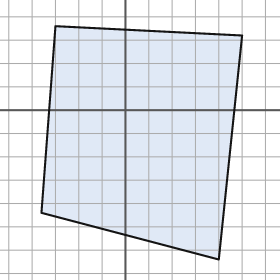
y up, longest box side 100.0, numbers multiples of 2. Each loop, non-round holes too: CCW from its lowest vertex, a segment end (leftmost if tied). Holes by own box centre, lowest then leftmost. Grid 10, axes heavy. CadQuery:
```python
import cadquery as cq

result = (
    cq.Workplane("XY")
    .moveTo(40.0, -64.0)
    .lineTo(50.0, 32.0)
    .lineTo(-30.0, 36.0)
    .lineTo(-36.0, -44.0)
    .close()
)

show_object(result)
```